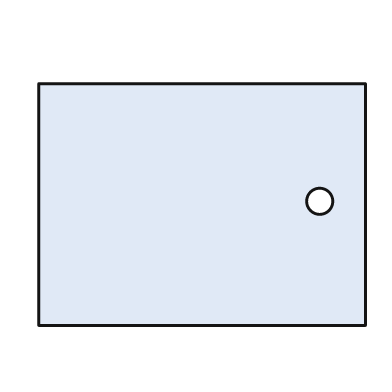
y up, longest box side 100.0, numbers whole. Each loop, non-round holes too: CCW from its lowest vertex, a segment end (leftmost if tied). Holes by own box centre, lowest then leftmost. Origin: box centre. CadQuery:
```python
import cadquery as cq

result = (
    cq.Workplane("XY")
    .moveTo(-50.0, -37.0)
    .lineTo(50.0, -37.0)
    .lineTo(50.0, 37.0)
    .lineTo(-50.0, 37.0)
    .close()
    .moveTo(36.0, 1.0)
    .circle(4.0)
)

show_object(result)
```